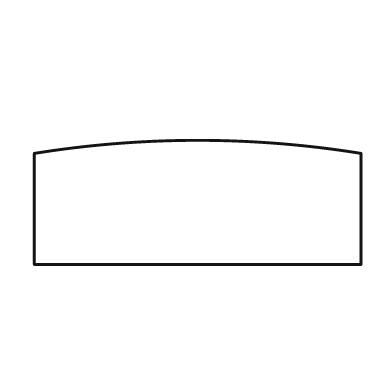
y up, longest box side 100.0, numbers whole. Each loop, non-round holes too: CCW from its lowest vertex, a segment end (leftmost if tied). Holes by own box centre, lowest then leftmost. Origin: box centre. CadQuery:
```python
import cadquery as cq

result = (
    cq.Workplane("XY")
    .moveTo(-50.0, -19.0)
    .lineTo(50.0, -19.0)
    .lineTo(50.0, 15.0)
    .threePointArc((0.0, 19.0), (-50.0, 15.0))
    .close()
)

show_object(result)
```